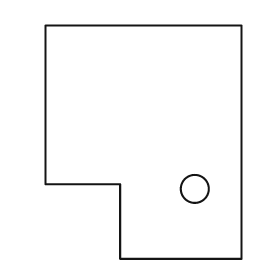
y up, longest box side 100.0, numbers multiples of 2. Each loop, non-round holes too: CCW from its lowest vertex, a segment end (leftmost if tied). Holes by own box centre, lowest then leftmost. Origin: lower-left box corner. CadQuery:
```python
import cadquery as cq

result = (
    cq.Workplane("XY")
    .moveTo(32.0, 0.0)
    .lineTo(84.0, 0.0)
    .lineTo(84.0, 100.0)
    .lineTo(0.0, 100.0)
    .lineTo(0.0, 32.0)
    .lineTo(32.0, 32.0)
    .close()
    .moveTo(64.0, 30.0)
    .circle(6.0)
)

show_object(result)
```